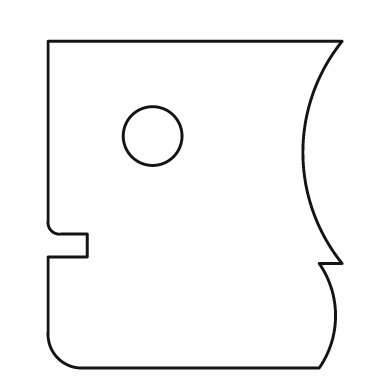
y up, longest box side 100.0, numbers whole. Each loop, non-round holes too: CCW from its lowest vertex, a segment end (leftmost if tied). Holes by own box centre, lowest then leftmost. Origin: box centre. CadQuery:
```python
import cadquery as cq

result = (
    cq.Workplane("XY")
    .moveTo(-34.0, -50.0)
    .lineTo(38.0, -50.0)
    .threePointArc((43.0, -34.0), (38.0, -18.0))
    .lineTo(45.0, -18.0)
    .threePointArc((33.0, 16.0), (45.0, 50.0))
    .lineTo(-45.0, 50.0)
    .lineTo(-45.0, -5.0)
    .threePointArc((-44.0, -8.0), (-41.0, -9.0))
    .lineTo(-33.0, -9.0)
    .lineTo(-33.0, -16.0)
    .lineTo(-45.0, -16.0)
    .lineTo(-45.0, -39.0)
    .threePointArc((-42.0, -47.0), (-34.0, -50.0))
    .close()
    .moveTo(-13.0, 21.0)
    .circle(9.0)
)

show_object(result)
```